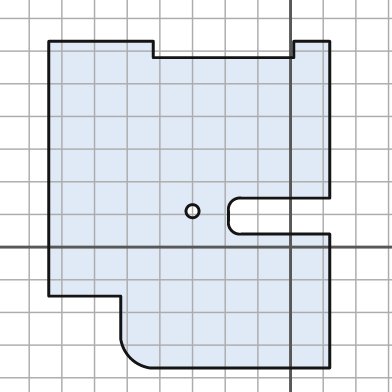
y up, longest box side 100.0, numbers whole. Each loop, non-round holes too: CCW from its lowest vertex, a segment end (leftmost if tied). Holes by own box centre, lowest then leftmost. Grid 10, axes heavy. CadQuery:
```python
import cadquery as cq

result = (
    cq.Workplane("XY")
    .moveTo(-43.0, -37.0)
    .lineTo(12.0, -37.0)
    .lineTo(12.0, 4.0)
    .lineTo(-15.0, 4.0)
    .threePointArc((-18.0, 5.0), (-19.0, 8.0))
    .lineTo(-19.0, 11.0)
    .threePointArc((-18.0, 14.0), (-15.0, 15.0))
    .lineTo(12.0, 15.0)
    .lineTo(12.0, 63.0)
    .lineTo(1.0, 63.0)
    .lineTo(1.0, 58.0)
    .lineTo(-42.0, 58.0)
    .lineTo(-42.0, 63.0)
    .lineTo(-74.0, 63.0)
    .lineTo(-74.0, -15.0)
    .lineTo(-52.0, -15.0)
    .lineTo(-52.0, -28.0)
    .threePointArc((-49.0, -34.0), (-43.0, -37.0))
    .close()
    .moveTo(-30.0, 11.0)
    .circle(2.0)
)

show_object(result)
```